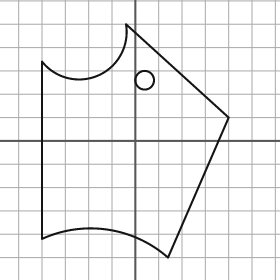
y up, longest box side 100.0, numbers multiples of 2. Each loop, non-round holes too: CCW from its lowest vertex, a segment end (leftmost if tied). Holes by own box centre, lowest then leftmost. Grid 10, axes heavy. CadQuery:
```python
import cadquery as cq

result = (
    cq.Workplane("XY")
    .moveTo(14.0, -50.0)
    .lineTo(40.0, 10.0)
    .lineTo(-4.0, 50.0)
    .threePointArc((-16.0, 28.0), (-40.0, 34.0))
    .lineTo(-40.0, -42.0)
    .threePointArc((-12.0, -38.0), (14.0, -50.0))
    .close()
    .moveTo(4.0, 26.0)
    .circle(4.0)
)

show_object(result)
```